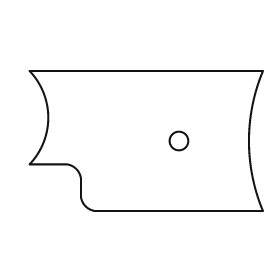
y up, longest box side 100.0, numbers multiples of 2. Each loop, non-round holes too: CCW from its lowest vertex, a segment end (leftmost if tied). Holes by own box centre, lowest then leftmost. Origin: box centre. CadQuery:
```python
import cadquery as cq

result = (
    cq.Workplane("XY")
    .moveTo(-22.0, -30.0)
    .lineTo(50.0, -30.0)
    .threePointArc((44.0, 0.0), (50.0, 30.0))
    .lineTo(-50.0, 30.0)
    .threePointArc((-42.0, 10.0), (-50.0, -10.0))
    .lineTo(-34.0, -10.0)
    .threePointArc((-30.0, -12.0), (-28.0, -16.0))
    .lineTo(-28.0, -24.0)
    .threePointArc((-26.0, -28.0), (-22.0, -30.0))
    .close()
    .moveTo(14.0, 0.0)
    .circle(4.0)
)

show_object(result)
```